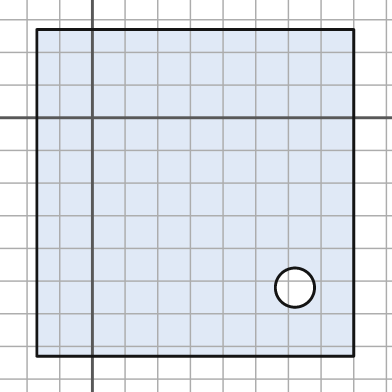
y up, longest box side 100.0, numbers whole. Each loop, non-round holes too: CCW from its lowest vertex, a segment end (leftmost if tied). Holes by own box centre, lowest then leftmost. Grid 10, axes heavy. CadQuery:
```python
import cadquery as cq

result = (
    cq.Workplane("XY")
    .moveTo(-17.0, -73.0)
    .lineTo(80.0, -73.0)
    .lineTo(80.0, 27.0)
    .lineTo(-17.0, 27.0)
    .close()
    .moveTo(62.0, -52.0)
    .circle(6.0)
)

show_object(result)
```